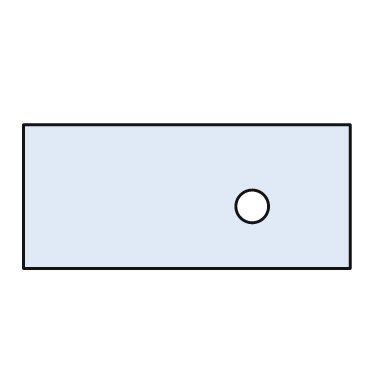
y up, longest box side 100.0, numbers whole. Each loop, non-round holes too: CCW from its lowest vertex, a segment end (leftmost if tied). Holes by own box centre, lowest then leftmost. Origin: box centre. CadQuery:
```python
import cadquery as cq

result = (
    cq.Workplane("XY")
    .moveTo(-50.0, -22.0)
    .lineTo(50.0, -22.0)
    .lineTo(50.0, 22.0)
    .lineTo(-50.0, 22.0)
    .close()
    .moveTo(20.0, -3.0)
    .circle(5.0)
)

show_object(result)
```